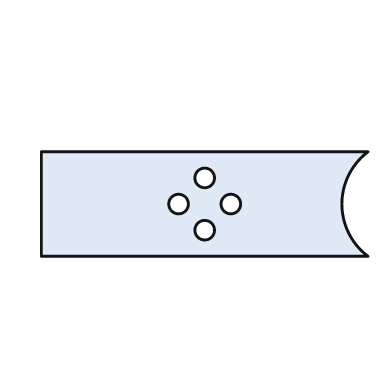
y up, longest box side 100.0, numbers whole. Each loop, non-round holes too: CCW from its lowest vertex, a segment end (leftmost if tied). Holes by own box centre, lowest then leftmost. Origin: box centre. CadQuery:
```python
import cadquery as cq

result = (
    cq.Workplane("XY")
    .moveTo(-50.0, -16.0)
    .lineTo(50.0, -16.0)
    .threePointArc((42.0, 0.0), (50.0, 16.0))
    .lineTo(-50.0, 16.0)
    .close()
    .moveTo(0.0, -8.0)
    .circle(3.0)
    .moveTo(-8.0, 0.0)
    .circle(3.0)
    .moveTo(8.0, 0.0)
    .circle(3.0)
    .moveTo(0.0, 8.0)
    .circle(3.0)
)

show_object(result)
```